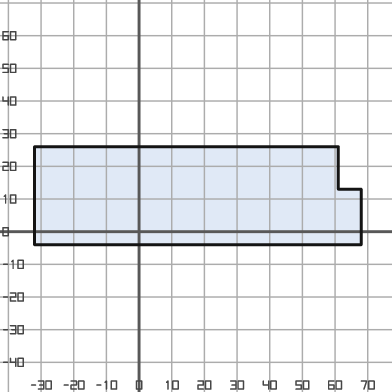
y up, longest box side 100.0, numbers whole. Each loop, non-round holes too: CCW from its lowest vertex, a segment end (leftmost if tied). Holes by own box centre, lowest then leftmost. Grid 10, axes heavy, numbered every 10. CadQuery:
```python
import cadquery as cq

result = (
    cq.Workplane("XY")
    .moveTo(-32.0, -4.0)
    .lineTo(68.0, -4.0)
    .lineTo(68.0, 13.0)
    .lineTo(61.0, 13.0)
    .lineTo(61.0, 26.0)
    .lineTo(-32.0, 26.0)
    .close()
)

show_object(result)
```